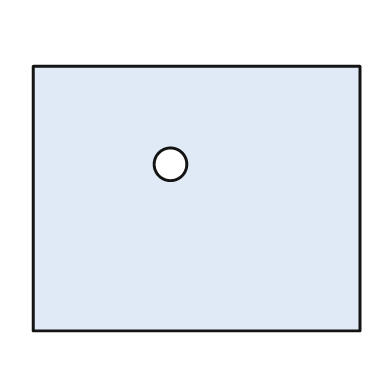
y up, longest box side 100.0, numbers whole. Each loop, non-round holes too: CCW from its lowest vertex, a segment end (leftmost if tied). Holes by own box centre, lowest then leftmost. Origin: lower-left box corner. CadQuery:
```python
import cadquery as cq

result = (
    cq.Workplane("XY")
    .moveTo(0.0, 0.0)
    .lineTo(100.0, 0.0)
    .lineTo(100.0, 81.0)
    .lineTo(0.0, 81.0)
    .close()
    .moveTo(42.0, 51.0)
    .circle(5.0)
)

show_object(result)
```